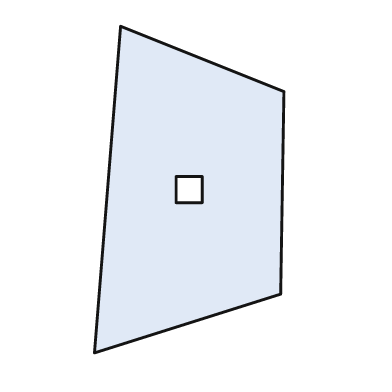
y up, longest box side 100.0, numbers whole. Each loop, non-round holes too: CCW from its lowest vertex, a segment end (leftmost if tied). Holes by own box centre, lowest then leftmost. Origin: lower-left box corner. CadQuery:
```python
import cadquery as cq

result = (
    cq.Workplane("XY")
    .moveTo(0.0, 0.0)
    .lineTo(57.0, 18.0)
    .lineTo(58.0, 80.0)
    .lineTo(8.0, 100.0)
    .close()
    .moveTo(25.0, 46.0)
    .lineTo(33.0, 46.0)
    .lineTo(33.0, 54.0)
    .lineTo(25.0, 54.0)
    .close()
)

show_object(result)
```